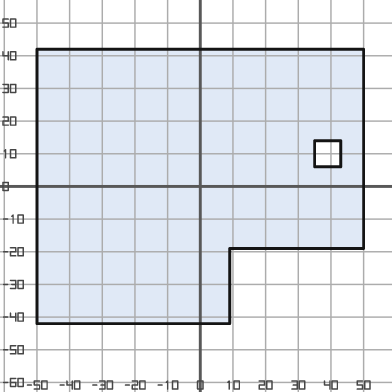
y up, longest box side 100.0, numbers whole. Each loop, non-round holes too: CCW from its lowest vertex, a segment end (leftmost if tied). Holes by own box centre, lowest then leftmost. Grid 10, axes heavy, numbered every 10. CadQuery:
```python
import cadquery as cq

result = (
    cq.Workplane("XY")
    .moveTo(-50.0, -42.0)
    .lineTo(9.0, -42.0)
    .lineTo(9.0, -19.0)
    .lineTo(50.0, -19.0)
    .lineTo(50.0, 42.0)
    .lineTo(-50.0, 42.0)
    .close()
    .moveTo(35.0, 6.0)
    .lineTo(43.0, 6.0)
    .lineTo(43.0, 14.0)
    .lineTo(35.0, 14.0)
    .close()
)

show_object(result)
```